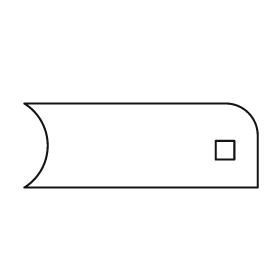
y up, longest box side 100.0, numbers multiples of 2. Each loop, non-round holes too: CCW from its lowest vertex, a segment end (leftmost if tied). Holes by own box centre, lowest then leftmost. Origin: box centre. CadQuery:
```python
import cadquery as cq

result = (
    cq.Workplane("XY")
    .moveTo(-50.0, -18.0)
    .lineTo(50.0, -18.0)
    .lineTo(50.0, 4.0)
    .threePointArc((46.0, 14.0), (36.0, 18.0))
    .lineTo(-50.0, 18.0)
    .threePointArc((-40.0, 0.0), (-50.0, -18.0))
    .close()
    .moveTo(32.0, -6.0)
    .lineTo(40.0, -6.0)
    .lineTo(40.0, 2.0)
    .lineTo(32.0, 2.0)
    .close()
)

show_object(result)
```